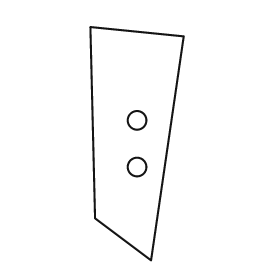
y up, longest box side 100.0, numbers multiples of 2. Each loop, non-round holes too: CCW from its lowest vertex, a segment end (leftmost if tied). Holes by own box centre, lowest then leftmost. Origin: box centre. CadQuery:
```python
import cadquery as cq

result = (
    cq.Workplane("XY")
    .moveTo(6.0, -50.0)
    .lineTo(20.0, 46.0)
    .lineTo(-20.0, 50.0)
    .lineTo(-18.0, -32.0)
    .close()
    .moveTo(0.0, -10.0)
    .circle(4.0)
    .moveTo(0.0, 10.0)
    .circle(4.0)
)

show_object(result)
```